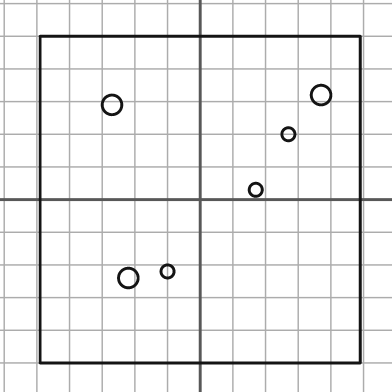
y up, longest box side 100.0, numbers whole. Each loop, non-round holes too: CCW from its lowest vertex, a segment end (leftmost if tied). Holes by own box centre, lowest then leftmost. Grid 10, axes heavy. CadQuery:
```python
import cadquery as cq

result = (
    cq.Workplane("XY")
    .moveTo(-49.0, -50.0)
    .lineTo(49.0, -50.0)
    .lineTo(49.0, 50.0)
    .lineTo(-49.0, 50.0)
    .close()
    .moveTo(-22.0, -24.0)
    .circle(3.0)
    .moveTo(-10.0, -22.0)
    .circle(2.0)
    .moveTo(17.0, 3.0)
    .circle(2.0)
    .moveTo(27.0, 20.0)
    .circle(2.0)
    .moveTo(-27.0, 29.0)
    .circle(3.0)
    .moveTo(37.0, 32.0)
    .circle(3.0)
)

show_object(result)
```